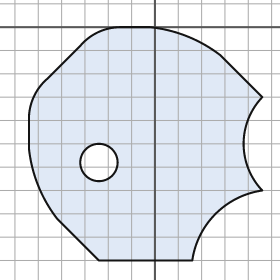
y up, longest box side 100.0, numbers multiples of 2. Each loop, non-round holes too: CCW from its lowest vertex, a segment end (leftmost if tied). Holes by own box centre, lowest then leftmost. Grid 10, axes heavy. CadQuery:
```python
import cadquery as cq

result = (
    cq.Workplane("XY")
    .moveTo(-24.0, -100.0)
    .lineTo(16.0, -100.0)
    .threePointArc((26.0, -80.0), (46.0, -70.0))
    .threePointArc((38.0, -50.0), (46.0, -30.0))
    .lineTo(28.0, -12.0)
    .threePointArc((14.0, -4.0), (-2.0, 0.0))
    .lineTo(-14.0, 0.0)
    .threePointArc((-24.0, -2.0), (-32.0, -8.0))
    .lineTo(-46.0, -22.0)
    .threePointArc((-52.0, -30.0), (-54.0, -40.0))
    .lineTo(-54.0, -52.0)
    .threePointArc((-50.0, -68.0), (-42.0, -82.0))
    .close()
    .moveTo(-24.0, -58.0)
    .circle(8.0)
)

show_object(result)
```